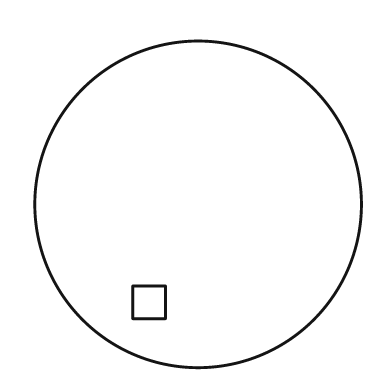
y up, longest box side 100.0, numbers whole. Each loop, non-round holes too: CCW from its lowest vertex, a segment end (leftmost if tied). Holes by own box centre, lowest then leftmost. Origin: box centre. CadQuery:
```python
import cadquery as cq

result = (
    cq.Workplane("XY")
    .moveTo(0.0, 0.0)
    .circle(50.0)
    .moveTo(-20.0, -35.0)
    .lineTo(-10.0, -35.0)
    .lineTo(-10.0, -25.0)
    .lineTo(-20.0, -25.0)
    .close()
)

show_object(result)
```